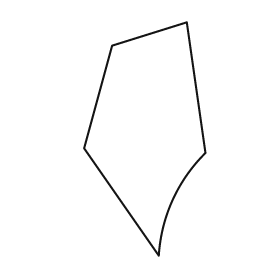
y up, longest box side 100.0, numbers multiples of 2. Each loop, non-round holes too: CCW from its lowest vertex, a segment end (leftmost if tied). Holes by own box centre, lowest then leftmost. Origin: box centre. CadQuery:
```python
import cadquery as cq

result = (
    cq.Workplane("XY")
    .moveTo(6.0, -50.0)
    .threePointArc((12.0, -26.0), (26.0, -6.0))
    .lineTo(18.0, 50.0)
    .lineTo(-14.0, 40.0)
    .lineTo(-26.0, -4.0)
    .close()
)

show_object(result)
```